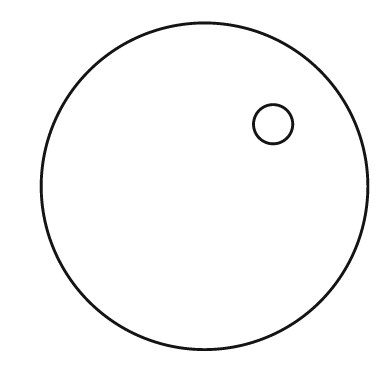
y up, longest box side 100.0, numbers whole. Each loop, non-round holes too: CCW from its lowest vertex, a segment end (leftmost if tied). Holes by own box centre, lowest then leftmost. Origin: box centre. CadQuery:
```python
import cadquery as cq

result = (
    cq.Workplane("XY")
    .moveTo(0.0, 0.0)
    .circle(50.0)
    .moveTo(21.0, 19.0)
    .circle(6.0)
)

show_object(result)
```